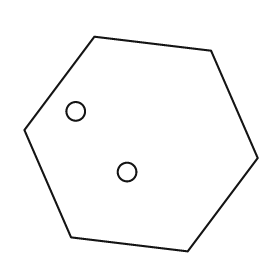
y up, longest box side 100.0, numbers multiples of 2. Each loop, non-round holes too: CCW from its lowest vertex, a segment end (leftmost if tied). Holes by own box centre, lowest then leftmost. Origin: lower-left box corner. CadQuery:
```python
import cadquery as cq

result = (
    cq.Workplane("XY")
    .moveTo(70.0, 0.0)
    .lineTo(100.0, 40.0)
    .lineTo(80.0, 86.0)
    .lineTo(30.0, 92.0)
    .lineTo(0.0, 52.0)
    .lineTo(20.0, 6.0)
    .close()
    .moveTo(44.0, 34.0)
    .circle(4.0)
    .moveTo(22.0, 60.0)
    .circle(4.0)
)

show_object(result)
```